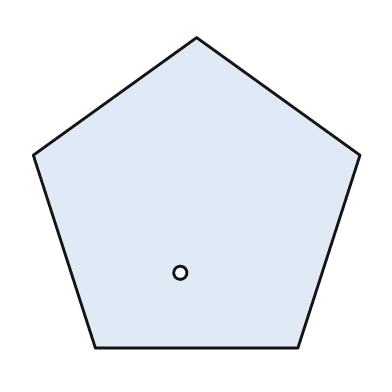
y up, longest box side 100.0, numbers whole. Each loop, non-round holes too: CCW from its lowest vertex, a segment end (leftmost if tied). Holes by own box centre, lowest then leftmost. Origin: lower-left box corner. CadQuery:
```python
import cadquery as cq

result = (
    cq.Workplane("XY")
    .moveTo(19.0, 0.0)
    .lineTo(81.0, 0.0)
    .lineTo(100.0, 59.0)
    .lineTo(50.0, 95.0)
    .lineTo(0.0, 59.0)
    .close()
    .moveTo(45.0, 23.0)
    .circle(2.0)
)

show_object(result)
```